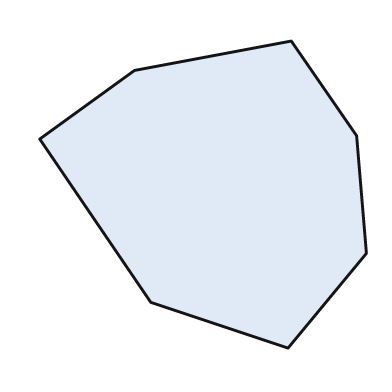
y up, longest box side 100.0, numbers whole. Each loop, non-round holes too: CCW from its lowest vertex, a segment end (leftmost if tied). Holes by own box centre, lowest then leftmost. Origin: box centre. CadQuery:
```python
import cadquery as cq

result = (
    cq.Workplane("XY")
    .moveTo(26.0, -47.0)
    .lineTo(50.0, -18.0)
    .lineTo(47.0, 18.0)
    .lineTo(27.0, 47.0)
    .lineTo(-21.0, 38.0)
    .lineTo(-50.0, 17.0)
    .lineTo(-16.0, -33.0)
    .close()
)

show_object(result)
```